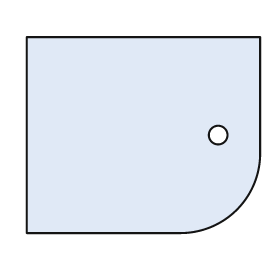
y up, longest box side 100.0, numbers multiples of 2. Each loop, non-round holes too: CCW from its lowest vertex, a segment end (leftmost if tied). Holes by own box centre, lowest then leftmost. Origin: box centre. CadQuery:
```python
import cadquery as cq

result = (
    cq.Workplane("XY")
    .moveTo(-50.0, -42.0)
    .lineTo(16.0, -42.0)
    .threePointArc((40.0, -32.0), (50.0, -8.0))
    .lineTo(50.0, 42.0)
    .lineTo(-50.0, 42.0)
    .close()
    .moveTo(32.0, 0.0)
    .circle(4.0)
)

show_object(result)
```